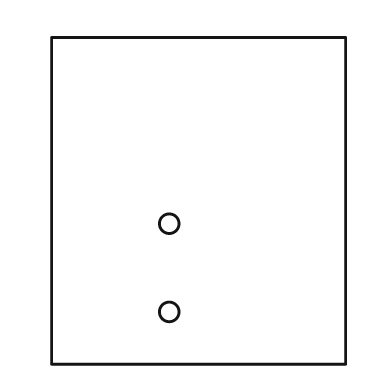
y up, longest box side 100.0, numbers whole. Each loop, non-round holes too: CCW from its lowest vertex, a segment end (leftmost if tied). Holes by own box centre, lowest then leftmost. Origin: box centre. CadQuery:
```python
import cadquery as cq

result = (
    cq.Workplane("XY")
    .moveTo(-45.0, -50.0)
    .lineTo(45.0, -50.0)
    .lineTo(45.0, 50.0)
    .lineTo(-45.0, 50.0)
    .close()
    .moveTo(-9.0, -34.0)
    .circle(3.0)
    .moveTo(-9.0, -7.0)
    .circle(3.0)
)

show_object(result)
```